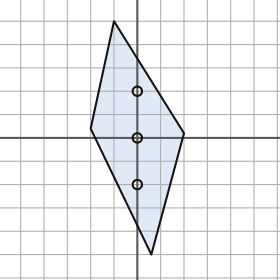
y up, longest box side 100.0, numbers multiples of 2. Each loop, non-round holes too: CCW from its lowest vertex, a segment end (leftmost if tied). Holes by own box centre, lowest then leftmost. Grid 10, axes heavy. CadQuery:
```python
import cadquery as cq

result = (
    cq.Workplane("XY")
    .moveTo(6.0, -50.0)
    .lineTo(20.0, 2.0)
    .lineTo(-10.0, 50.0)
    .lineTo(-20.0, 4.0)
    .close()
    .moveTo(0.0, -20.0)
    .circle(2.0)
    .moveTo(0.0, 0.0)
    .circle(2.0)
    .moveTo(0.0, 20.0)
    .circle(2.0)
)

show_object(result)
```